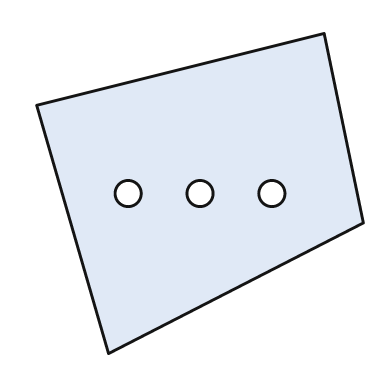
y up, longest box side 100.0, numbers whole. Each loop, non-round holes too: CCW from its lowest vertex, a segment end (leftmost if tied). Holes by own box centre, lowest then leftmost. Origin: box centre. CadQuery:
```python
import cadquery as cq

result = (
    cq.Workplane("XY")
    .moveTo(-28.0, -49.0)
    .lineTo(50.0, -9.0)
    .lineTo(38.0, 49.0)
    .lineTo(-50.0, 27.0)
    .close()
    .moveTo(-22.0, 0.0)
    .circle(4.0)
    .moveTo(0.0, 0.0)
    .circle(4.0)
    .moveTo(22.0, 0.0)
    .circle(4.0)
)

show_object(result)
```